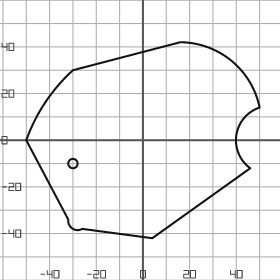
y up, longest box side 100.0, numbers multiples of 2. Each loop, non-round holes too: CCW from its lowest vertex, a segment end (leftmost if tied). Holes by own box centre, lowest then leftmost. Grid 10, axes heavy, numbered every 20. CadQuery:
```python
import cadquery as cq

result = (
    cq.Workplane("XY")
    .moveTo(4.0, -42.0)
    .lineTo(46.0, -12.0)
    .threePointArc((40.0, 2.0), (50.0, 14.0))
    .threePointArc((38.0, 34.0), (16.0, 42.0))
    .lineTo(-30.0, 30.0)
    .threePointArc((-42.0, 16.0), (-50.0, 0.0))
    .lineTo(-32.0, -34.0)
    .threePointArc((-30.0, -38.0), (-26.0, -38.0))
    .close()
    .moveTo(-30.0, -10.0)
    .circle(2.0)
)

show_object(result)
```